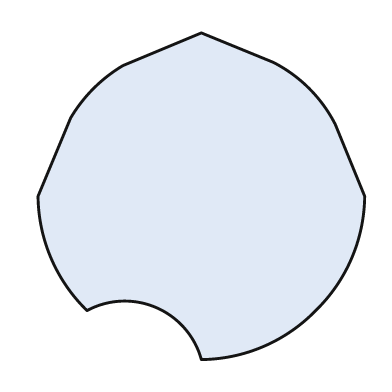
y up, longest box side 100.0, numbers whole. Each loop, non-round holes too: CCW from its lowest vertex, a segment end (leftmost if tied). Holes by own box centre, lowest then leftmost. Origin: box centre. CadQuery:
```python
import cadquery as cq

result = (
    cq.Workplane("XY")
    .moveTo(0.0, -50.0)
    .threePointArc((19.0, -46.0), (35.0, -35.0))
    .threePointArc((46.0, -19.0), (50.0, 0.0))
    .lineTo(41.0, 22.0)
    .threePointArc((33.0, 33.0), (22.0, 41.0))
    .lineTo(0.0, 50.0)
    .lineTo(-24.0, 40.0)
    .threePointArc((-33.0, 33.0), (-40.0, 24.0))
    .lineTo(-50.0, 0.0)
    .threePointArc((-46.0, -19.0), (-35.0, -35.0))
    .threePointArc((-14.0, -34.0), (0.0, -50.0))
    .close()
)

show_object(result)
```